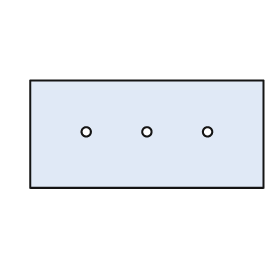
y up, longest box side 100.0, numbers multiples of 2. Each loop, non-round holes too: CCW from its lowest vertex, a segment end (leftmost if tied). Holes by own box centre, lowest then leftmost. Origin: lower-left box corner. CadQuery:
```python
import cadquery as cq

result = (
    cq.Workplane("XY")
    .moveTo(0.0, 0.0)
    .lineTo(100.0, 0.0)
    .lineTo(100.0, 46.0)
    .lineTo(0.0, 46.0)
    .close()
    .moveTo(24.0, 24.0)
    .circle(2.0)
    .moveTo(50.0, 24.0)
    .circle(2.0)
    .moveTo(76.0, 24.0)
    .circle(2.0)
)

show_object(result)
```